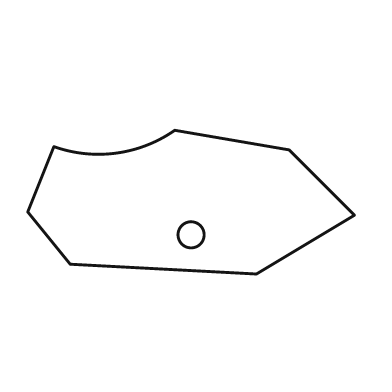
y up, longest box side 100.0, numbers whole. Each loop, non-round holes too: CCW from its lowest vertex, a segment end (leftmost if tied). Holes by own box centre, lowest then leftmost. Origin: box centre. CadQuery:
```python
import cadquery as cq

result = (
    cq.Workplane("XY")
    .moveTo(20.0, -22.0)
    .lineTo(50.0, -4.0)
    .lineTo(30.0, 16.0)
    .lineTo(-5.0, 22.0)
    .threePointArc((-23.0, 15.0), (-42.0, 17.0))
    .lineTo(-50.0, -3.0)
    .lineTo(-37.0, -19.0)
    .close()
    .moveTo(0.0, -10.0)
    .circle(4.0)
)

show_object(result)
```